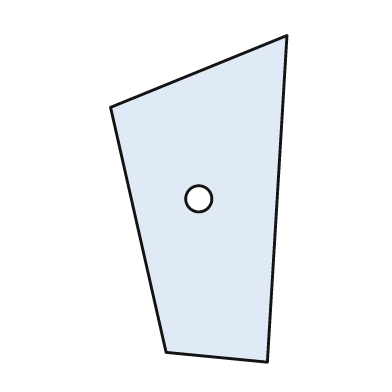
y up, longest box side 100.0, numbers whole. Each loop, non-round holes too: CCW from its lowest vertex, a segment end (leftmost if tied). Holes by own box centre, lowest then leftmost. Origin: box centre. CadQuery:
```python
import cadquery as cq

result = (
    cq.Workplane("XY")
    .moveTo(21.0, -50.0)
    .lineTo(27.0, 50.0)
    .lineTo(-27.0, 28.0)
    .lineTo(-10.0, -47.0)
    .close()
    .moveTo(0.0, 0.0)
    .circle(4.0)
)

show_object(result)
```